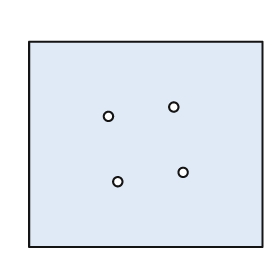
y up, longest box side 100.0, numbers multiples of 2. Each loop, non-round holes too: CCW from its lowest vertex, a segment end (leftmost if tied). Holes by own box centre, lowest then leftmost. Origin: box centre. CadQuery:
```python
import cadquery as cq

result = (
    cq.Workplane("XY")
    .moveTo(-50.0, -44.0)
    .lineTo(50.0, -44.0)
    .lineTo(50.0, 44.0)
    .lineTo(-50.0, 44.0)
    .close()
    .moveTo(-12.0, -16.0)
    .circle(2.0)
    .moveTo(16.0, -12.0)
    .circle(2.0)
    .moveTo(-16.0, 12.0)
    .circle(2.0)
    .moveTo(12.0, 16.0)
    .circle(2.0)
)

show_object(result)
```